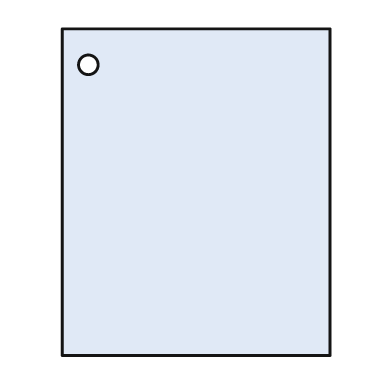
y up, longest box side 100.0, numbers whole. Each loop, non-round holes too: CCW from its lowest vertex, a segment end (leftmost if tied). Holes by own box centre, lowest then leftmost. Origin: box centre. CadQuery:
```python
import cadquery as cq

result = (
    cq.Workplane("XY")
    .moveTo(-41.0, -50.0)
    .lineTo(41.0, -50.0)
    .lineTo(41.0, 50.0)
    .lineTo(-41.0, 50.0)
    .close()
    .moveTo(-33.0, 39.0)
    .circle(3.0)
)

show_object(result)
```